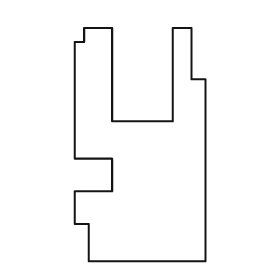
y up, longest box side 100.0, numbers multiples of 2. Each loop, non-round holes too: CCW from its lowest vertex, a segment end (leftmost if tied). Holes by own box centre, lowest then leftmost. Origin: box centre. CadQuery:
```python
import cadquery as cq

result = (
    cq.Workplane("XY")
    .moveTo(-22.0, -50.0)
    .lineTo(28.0, -50.0)
    .lineTo(28.0, 28.0)
    .lineTo(22.0, 28.0)
    .lineTo(22.0, 50.0)
    .lineTo(14.0, 50.0)
    .lineTo(14.0, 10.0)
    .lineTo(-12.0, 10.0)
    .lineTo(-12.0, 50.0)
    .lineTo(-24.0, 50.0)
    .lineTo(-24.0, 44.0)
    .lineTo(-28.0, 44.0)
    .lineTo(-28.0, -6.0)
    .lineTo(-12.0, -6.0)
    .lineTo(-12.0, -20.0)
    .lineTo(-28.0, -20.0)
    .lineTo(-28.0, -34.0)
    .lineTo(-22.0, -34.0)
    .close()
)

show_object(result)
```